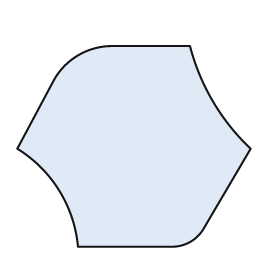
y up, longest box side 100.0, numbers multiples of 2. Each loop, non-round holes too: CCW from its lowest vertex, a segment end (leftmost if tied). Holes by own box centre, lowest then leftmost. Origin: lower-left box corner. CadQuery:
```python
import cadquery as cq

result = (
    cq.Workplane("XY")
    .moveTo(26.0, 0.0)
    .lineTo(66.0, 0.0)
    .threePointArc((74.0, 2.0), (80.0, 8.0))
    .lineTo(100.0, 42.0)
    .threePointArc((84.0, 62.0), (74.0, 86.0))
    .lineTo(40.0, 86.0)
    .threePointArc((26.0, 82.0), (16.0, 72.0))
    .lineTo(0.0, 42.0)
    .threePointArc((18.0, 24.0), (26.0, 0.0))
    .close()
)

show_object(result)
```